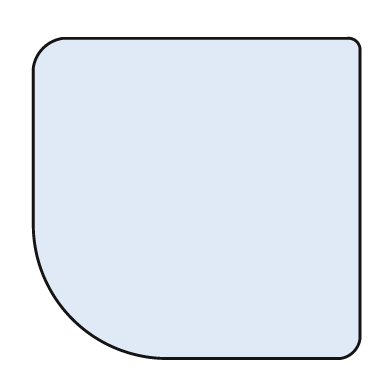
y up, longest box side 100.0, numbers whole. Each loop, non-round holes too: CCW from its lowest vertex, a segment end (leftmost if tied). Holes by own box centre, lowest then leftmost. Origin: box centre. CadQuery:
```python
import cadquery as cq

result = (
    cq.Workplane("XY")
    .moveTo(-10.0, -49.0)
    .lineTo(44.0, -49.0)
    .threePointArc((48.0, -47.0), (50.0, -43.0))
    .lineTo(50.0, 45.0)
    .threePointArc((49.0, 48.0), (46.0, 49.0))
    .lineTo(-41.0, 49.0)
    .threePointArc((-47.0, 46.0), (-50.0, 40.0))
    .lineTo(-50.0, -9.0)
    .threePointArc((-38.0, -37.0), (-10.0, -49.0))
    .close()
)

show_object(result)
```